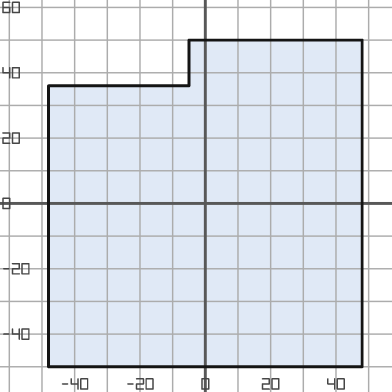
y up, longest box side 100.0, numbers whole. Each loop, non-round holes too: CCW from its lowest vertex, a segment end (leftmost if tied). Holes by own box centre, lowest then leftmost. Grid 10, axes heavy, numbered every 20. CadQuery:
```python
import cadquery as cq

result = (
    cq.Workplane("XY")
    .moveTo(-48.0, -50.0)
    .lineTo(48.0, -50.0)
    .lineTo(48.0, 50.0)
    .lineTo(-5.0, 50.0)
    .lineTo(-5.0, 36.0)
    .lineTo(-48.0, 36.0)
    .close()
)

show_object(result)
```